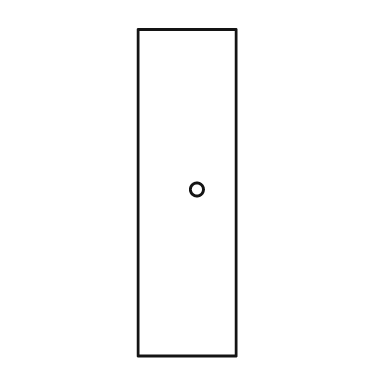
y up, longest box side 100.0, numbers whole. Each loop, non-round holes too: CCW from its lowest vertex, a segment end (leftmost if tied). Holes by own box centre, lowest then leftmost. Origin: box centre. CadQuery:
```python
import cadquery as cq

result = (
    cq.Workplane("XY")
    .moveTo(-15.0, -50.0)
    .lineTo(15.0, -50.0)
    .lineTo(15.0, 50.0)
    .lineTo(-15.0, 50.0)
    .close()
    .moveTo(3.0, 1.0)
    .circle(2.0)
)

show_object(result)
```